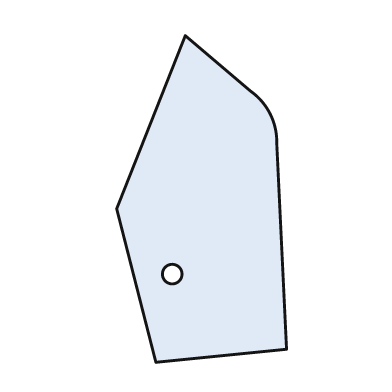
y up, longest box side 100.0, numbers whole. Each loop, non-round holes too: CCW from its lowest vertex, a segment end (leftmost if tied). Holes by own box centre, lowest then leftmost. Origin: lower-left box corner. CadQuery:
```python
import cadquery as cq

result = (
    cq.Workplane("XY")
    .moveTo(12.0, 0.0)
    .lineTo(52.0, 4.0)
    .lineTo(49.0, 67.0)
    .threePointArc((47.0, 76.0), (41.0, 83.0))
    .lineTo(21.0, 100.0)
    .lineTo(0.0, 47.0)
    .close()
    .moveTo(17.0, 27.0)
    .circle(3.0)
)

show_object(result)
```